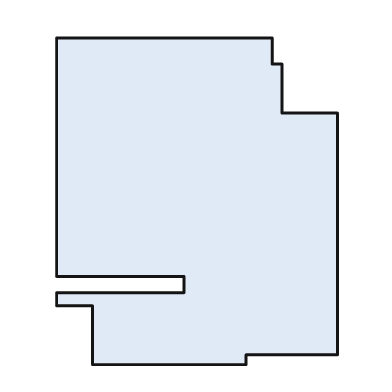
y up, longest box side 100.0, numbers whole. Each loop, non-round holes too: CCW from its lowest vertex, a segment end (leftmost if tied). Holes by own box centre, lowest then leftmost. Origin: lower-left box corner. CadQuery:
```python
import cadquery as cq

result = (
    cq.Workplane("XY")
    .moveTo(11.0, 0.0)
    .lineTo(58.0, 0.0)
    .lineTo(58.0, 3.0)
    .lineTo(86.0, 3.0)
    .lineTo(86.0, 77.0)
    .lineTo(69.0, 77.0)
    .lineTo(69.0, 92.0)
    .lineTo(66.0, 92.0)
    .lineTo(66.0, 100.0)
    .lineTo(0.0, 100.0)
    .lineTo(0.0, 27.0)
    .lineTo(39.0, 27.0)
    .lineTo(39.0, 22.0)
    .lineTo(0.0, 22.0)
    .lineTo(0.0, 18.0)
    .lineTo(11.0, 18.0)
    .close()
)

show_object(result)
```